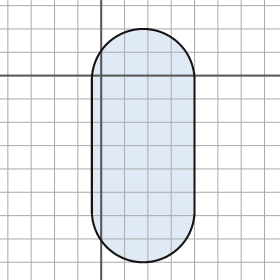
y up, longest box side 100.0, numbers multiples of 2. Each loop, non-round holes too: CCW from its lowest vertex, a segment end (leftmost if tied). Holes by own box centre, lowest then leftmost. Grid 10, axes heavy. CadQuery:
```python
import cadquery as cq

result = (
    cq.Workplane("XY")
    .moveTo(-4.0, -58.0)
    .threePointArc((18.0, -80.0), (40.0, -58.0))
    .lineTo(40.0, -2.0)
    .threePointArc((18.0, 20.0), (-4.0, -2.0))
    .close()
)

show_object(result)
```